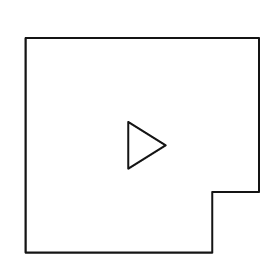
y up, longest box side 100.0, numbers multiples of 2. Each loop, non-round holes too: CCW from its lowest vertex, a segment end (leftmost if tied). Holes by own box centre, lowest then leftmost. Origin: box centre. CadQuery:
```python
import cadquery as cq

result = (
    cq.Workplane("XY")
    .moveTo(-50.0, -46.0)
    .lineTo(30.0, -46.0)
    .lineTo(30.0, -20.0)
    .lineTo(50.0, -20.0)
    .lineTo(50.0, 46.0)
    .lineTo(-50.0, 46.0)
    .close()
    .moveTo(-6.0, -10.0)
    .lineTo(10.0, 0.0)
    .lineTo(-6.0, 10.0)
    .close()
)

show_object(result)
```